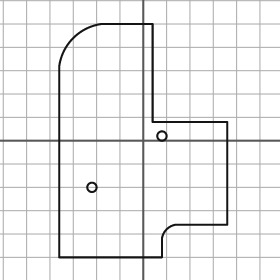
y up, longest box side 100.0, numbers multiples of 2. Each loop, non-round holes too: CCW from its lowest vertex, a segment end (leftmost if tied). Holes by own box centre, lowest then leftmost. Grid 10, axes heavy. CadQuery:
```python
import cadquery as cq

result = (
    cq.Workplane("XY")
    .moveTo(-36.0, -50.0)
    .lineTo(8.0, -50.0)
    .lineTo(8.0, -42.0)
    .threePointArc((10.0, -38.0), (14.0, -36.0))
    .lineTo(36.0, -36.0)
    .lineTo(36.0, 8.0)
    .lineTo(4.0, 8.0)
    .lineTo(4.0, 50.0)
    .lineTo(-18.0, 50.0)
    .threePointArc((-30.0, 44.0), (-36.0, 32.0))
    .close()
    .moveTo(-22.0, -20.0)
    .circle(2.0)
    .moveTo(8.0, 2.0)
    .circle(2.0)
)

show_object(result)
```